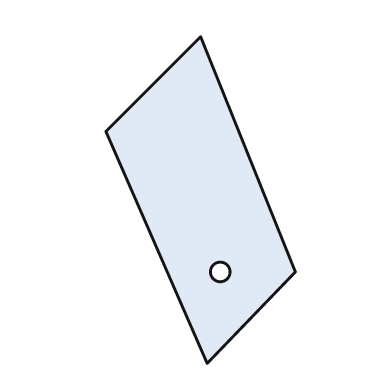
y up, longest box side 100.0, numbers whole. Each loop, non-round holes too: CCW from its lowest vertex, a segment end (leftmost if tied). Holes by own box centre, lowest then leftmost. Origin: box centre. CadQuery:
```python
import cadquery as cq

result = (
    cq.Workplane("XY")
    .moveTo(2.0, -50.0)
    .lineTo(29.0, -22.0)
    .lineTo(0.0, 50.0)
    .lineTo(-29.0, 21.0)
    .close()
    .moveTo(6.0, -22.0)
    .circle(3.0)
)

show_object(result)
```